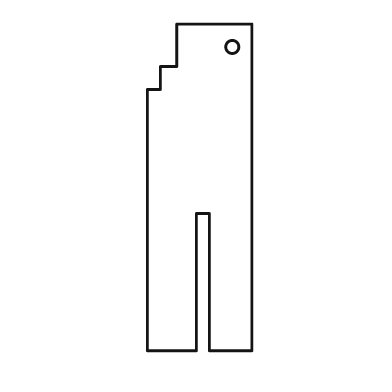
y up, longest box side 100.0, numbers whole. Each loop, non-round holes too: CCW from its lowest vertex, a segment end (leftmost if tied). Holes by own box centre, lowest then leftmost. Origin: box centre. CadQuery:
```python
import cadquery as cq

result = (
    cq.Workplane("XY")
    .moveTo(-16.0, -50.0)
    .lineTo(-1.0, -50.0)
    .lineTo(-1.0, -8.0)
    .lineTo(3.0, -8.0)
    .lineTo(3.0, -50.0)
    .lineTo(16.0, -50.0)
    .lineTo(16.0, 50.0)
    .lineTo(-7.0, 50.0)
    .lineTo(-7.0, 37.0)
    .lineTo(-12.0, 37.0)
    .lineTo(-12.0, 30.0)
    .lineTo(-16.0, 30.0)
    .close()
    .moveTo(10.0, 43.0)
    .circle(2.0)
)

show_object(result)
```